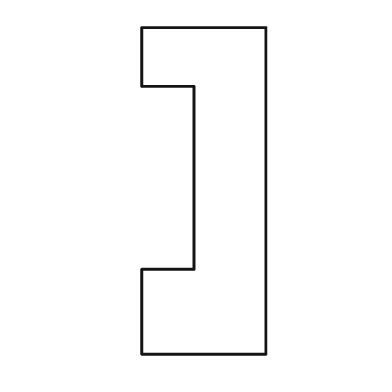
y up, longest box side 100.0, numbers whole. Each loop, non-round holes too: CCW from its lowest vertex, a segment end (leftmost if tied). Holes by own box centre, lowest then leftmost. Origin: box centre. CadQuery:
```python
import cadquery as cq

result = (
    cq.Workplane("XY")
    .moveTo(-19.0, -50.0)
    .lineTo(19.0, -50.0)
    .lineTo(19.0, 50.0)
    .lineTo(-19.0, 50.0)
    .lineTo(-19.0, 32.0)
    .lineTo(-3.0, 32.0)
    .lineTo(-3.0, -24.0)
    .lineTo(-19.0, -24.0)
    .close()
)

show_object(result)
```